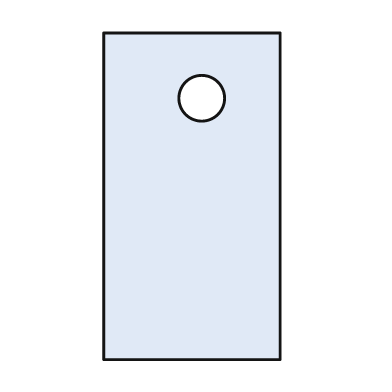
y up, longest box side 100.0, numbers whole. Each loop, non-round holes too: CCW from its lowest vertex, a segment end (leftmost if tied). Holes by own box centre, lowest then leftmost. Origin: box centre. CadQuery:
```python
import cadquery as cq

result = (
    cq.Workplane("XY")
    .moveTo(-27.0, -50.0)
    .lineTo(27.0, -50.0)
    .lineTo(27.0, 50.0)
    .lineTo(-27.0, 50.0)
    .close()
    .moveTo(3.0, 30.0)
    .circle(7.0)
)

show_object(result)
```